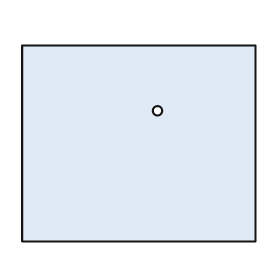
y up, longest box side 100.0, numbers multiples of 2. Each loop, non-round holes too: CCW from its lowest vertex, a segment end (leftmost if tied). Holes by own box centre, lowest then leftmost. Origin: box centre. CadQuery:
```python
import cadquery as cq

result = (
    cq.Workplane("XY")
    .moveTo(-50.0, -42.0)
    .lineTo(50.0, -42.0)
    .lineTo(50.0, 42.0)
    .lineTo(-50.0, 42.0)
    .close()
    .moveTo(8.0, 14.0)
    .circle(2.0)
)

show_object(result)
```